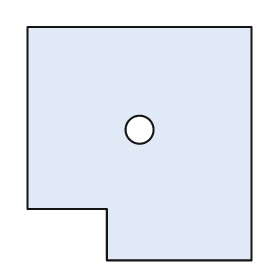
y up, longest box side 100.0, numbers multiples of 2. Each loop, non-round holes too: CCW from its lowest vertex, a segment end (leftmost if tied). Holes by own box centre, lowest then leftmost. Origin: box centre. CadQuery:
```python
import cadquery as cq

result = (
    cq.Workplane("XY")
    .moveTo(-14.0, -50.0)
    .lineTo(48.0, -50.0)
    .lineTo(48.0, 50.0)
    .lineTo(-48.0, 50.0)
    .lineTo(-48.0, -28.0)
    .lineTo(-14.0, -28.0)
    .close()
    .moveTo(0.0, 6.0)
    .circle(6.0)
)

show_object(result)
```